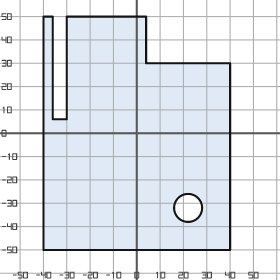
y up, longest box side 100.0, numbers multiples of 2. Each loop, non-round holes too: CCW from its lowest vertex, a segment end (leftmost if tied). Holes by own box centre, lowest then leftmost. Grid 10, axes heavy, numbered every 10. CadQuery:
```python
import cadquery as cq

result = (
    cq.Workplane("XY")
    .moveTo(-40.0, -50.0)
    .lineTo(40.0, -50.0)
    .lineTo(40.0, 30.0)
    .lineTo(4.0, 30.0)
    .lineTo(4.0, 50.0)
    .lineTo(-30.0, 50.0)
    .lineTo(-30.0, 6.0)
    .lineTo(-36.0, 6.0)
    .lineTo(-36.0, 50.0)
    .lineTo(-40.0, 50.0)
    .close()
    .moveTo(22.0, -32.0)
    .circle(6.0)
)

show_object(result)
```